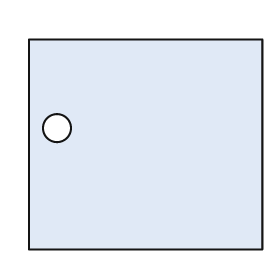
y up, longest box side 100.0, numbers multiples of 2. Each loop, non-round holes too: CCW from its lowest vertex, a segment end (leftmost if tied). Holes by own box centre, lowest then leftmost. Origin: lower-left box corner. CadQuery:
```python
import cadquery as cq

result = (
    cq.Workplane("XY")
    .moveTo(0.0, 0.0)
    .lineTo(100.0, 0.0)
    .lineTo(100.0, 90.0)
    .lineTo(0.0, 90.0)
    .close()
    .moveTo(12.0, 52.0)
    .circle(6.0)
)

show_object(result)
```